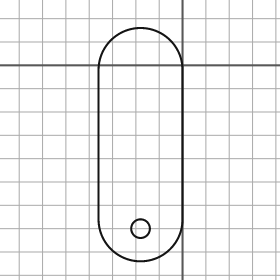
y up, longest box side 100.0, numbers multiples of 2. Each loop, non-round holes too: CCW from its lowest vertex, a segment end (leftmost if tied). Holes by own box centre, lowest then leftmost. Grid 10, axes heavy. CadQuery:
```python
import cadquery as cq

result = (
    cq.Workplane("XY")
    .moveTo(-36.0, -66.0)
    .threePointArc((-18.0, -84.0), (0.0, -66.0))
    .lineTo(0.0, -2.0)
    .threePointArc((-18.0, 16.0), (-36.0, -2.0))
    .close()
    .moveTo(-18.0, -70.0)
    .circle(4.0)
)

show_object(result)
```